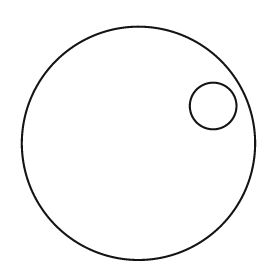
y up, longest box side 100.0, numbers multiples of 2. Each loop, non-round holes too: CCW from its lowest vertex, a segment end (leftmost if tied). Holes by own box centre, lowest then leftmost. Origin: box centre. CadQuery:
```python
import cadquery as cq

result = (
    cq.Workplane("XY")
    .moveTo(0.0, 0.0)
    .circle(50.0)
    .moveTo(32.0, 16.0)
    .circle(10.0)
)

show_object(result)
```